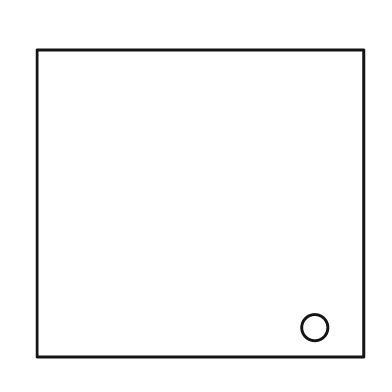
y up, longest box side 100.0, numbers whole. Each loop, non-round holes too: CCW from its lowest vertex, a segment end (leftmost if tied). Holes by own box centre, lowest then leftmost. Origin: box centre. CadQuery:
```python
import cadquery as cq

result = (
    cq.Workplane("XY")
    .moveTo(-50.0, -47.0)
    .lineTo(50.0, -47.0)
    .lineTo(50.0, 47.0)
    .lineTo(-50.0, 47.0)
    .close()
    .moveTo(35.0, -38.0)
    .circle(4.0)
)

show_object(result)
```